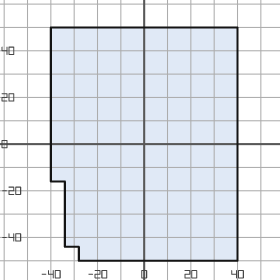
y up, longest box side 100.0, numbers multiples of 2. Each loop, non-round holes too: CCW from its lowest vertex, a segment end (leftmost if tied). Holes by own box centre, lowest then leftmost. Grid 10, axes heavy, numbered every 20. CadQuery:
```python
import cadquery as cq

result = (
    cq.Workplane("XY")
    .moveTo(-28.0, -50.0)
    .lineTo(40.0, -50.0)
    .lineTo(40.0, 50.0)
    .lineTo(-40.0, 50.0)
    .lineTo(-40.0, -16.0)
    .lineTo(-34.0, -16.0)
    .lineTo(-34.0, -44.0)
    .lineTo(-28.0, -44.0)
    .close()
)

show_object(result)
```